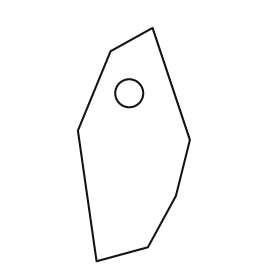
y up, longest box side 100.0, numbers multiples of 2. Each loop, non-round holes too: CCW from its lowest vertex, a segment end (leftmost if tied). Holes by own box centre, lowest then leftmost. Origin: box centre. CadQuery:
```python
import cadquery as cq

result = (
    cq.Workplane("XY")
    .moveTo(-16.0, -50.0)
    .lineTo(6.0, -44.0)
    .lineTo(18.0, -22.0)
    .lineTo(24.0, 2.0)
    .lineTo(8.0, 50.0)
    .lineTo(-10.0, 40.0)
    .lineTo(-24.0, 6.0)
    .close()
    .moveTo(-2.0, 22.0)
    .circle(6.0)
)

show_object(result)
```